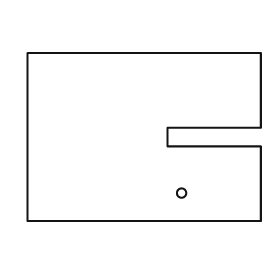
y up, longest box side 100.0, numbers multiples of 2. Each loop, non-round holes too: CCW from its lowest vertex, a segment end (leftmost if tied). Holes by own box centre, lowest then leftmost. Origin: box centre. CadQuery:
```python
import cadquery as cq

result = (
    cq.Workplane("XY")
    .moveTo(-50.0, -36.0)
    .lineTo(50.0, -36.0)
    .lineTo(50.0, -4.0)
    .lineTo(10.0, -4.0)
    .lineTo(10.0, 4.0)
    .lineTo(50.0, 4.0)
    .lineTo(50.0, 36.0)
    .lineTo(-50.0, 36.0)
    .close()
    .moveTo(16.0, -24.0)
    .circle(2.0)
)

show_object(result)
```